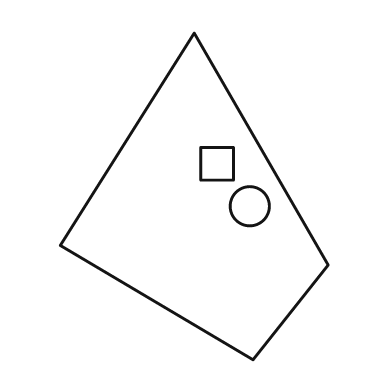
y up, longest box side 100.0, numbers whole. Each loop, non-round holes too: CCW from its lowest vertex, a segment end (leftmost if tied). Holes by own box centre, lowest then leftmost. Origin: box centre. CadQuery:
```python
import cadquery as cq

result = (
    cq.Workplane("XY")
    .moveTo(18.0, -50.0)
    .lineTo(41.0, -21.0)
    .lineTo(0.0, 50.0)
    .lineTo(-41.0, -15.0)
    .close()
    .moveTo(17.0, -3.0)
    .circle(6.0)
    .moveTo(2.0, 5.0)
    .lineTo(12.0, 5.0)
    .lineTo(12.0, 15.0)
    .lineTo(2.0, 15.0)
    .close()
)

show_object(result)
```